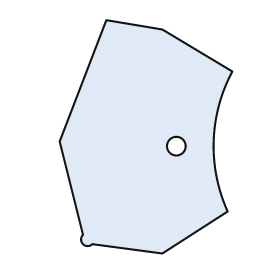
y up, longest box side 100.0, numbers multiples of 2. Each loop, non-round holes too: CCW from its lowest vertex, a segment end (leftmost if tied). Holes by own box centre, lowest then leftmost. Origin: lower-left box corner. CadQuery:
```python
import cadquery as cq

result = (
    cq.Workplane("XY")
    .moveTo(44.0, 0.0)
    .lineTo(72.0, 18.0)
    .threePointArc((66.0, 48.0), (74.0, 78.0))
    .lineTo(44.0, 96.0)
    .lineTo(20.0, 100.0)
    .lineTo(0.0, 48.0)
    .lineTo(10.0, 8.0)
    .threePointArc((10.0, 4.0), (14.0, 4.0))
    .close()
    .moveTo(50.0, 46.0)
    .circle(4.0)
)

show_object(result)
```